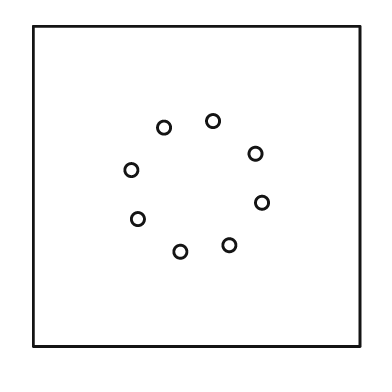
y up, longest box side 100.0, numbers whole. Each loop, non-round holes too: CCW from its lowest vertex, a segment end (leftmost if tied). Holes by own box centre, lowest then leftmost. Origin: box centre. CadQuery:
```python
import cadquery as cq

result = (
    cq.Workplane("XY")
    .moveTo(-50.0, -49.0)
    .lineTo(50.0, -49.0)
    .lineTo(50.0, 49.0)
    .lineTo(-50.0, 49.0)
    .close()
    .moveTo(-5.0, -20.0)
    .circle(2.0)
    .moveTo(10.0, -18.0)
    .circle(2.0)
    .moveTo(-18.0, -10.0)
    .circle(2.0)
    .moveTo(20.0, -5.0)
    .circle(2.0)
    .moveTo(-20.0, 5.0)
    .circle(2.0)
    .moveTo(18.0, 10.0)
    .circle(2.0)
    .moveTo(-10.0, 18.0)
    .circle(2.0)
    .moveTo(5.0, 20.0)
    .circle(2.0)
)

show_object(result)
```